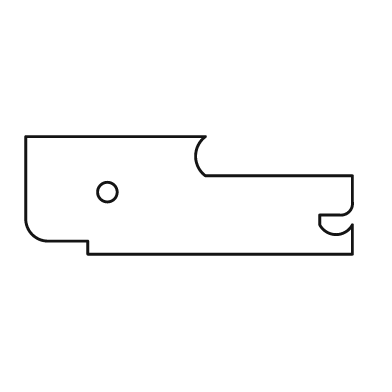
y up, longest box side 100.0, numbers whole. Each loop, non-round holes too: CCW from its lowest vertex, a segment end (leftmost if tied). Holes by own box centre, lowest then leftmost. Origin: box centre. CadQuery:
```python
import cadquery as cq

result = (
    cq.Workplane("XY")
    .moveTo(-31.0, -18.0)
    .lineTo(50.0, -18.0)
    .lineTo(50.0, -9.0)
    .threePointArc((45.0, -12.0), (40.0, -9.0))
    .lineTo(40.0, -6.0)
    .lineTo(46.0, -6.0)
    .threePointArc((49.0, -5.0), (50.0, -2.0))
    .lineTo(50.0, 6.0)
    .lineTo(5.0, 6.0)
    .threePointArc((2.0, 12.0), (5.0, 18.0))
    .lineTo(-50.0, 18.0)
    .lineTo(-50.0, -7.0)
    .threePointArc((-48.0, -12.0), (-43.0, -14.0))
    .lineTo(-31.0, -14.0)
    .close()
    .moveTo(-25.0, 1.0)
    .circle(3.0)
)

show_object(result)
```